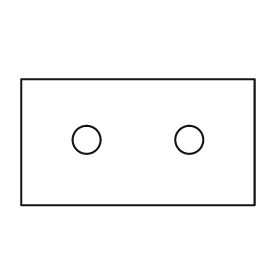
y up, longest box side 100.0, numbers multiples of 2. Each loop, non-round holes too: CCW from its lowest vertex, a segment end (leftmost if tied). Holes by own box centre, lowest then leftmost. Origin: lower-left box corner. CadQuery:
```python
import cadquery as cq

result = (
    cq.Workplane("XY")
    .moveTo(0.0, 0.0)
    .lineTo(100.0, 0.0)
    .lineTo(100.0, 54.0)
    .lineTo(0.0, 54.0)
    .close()
    .moveTo(28.0, 28.0)
    .circle(6.0)
    .moveTo(72.0, 28.0)
    .circle(6.0)
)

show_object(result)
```